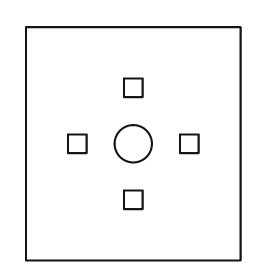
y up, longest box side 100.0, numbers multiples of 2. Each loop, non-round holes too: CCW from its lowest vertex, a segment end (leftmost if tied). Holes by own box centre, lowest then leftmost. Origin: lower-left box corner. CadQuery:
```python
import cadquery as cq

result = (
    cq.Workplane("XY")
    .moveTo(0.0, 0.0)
    .lineTo(92.0, 0.0)
    .lineTo(92.0, 100.0)
    .lineTo(0.0, 100.0)
    .close()
    .moveTo(42.0, 22.0)
    .lineTo(50.0, 22.0)
    .lineTo(50.0, 30.0)
    .lineTo(42.0, 30.0)
    .close()
    .moveTo(18.0, 46.0)
    .lineTo(26.0, 46.0)
    .lineTo(26.0, 54.0)
    .lineTo(18.0, 54.0)
    .close()
    .moveTo(46.0, 50.0)
    .circle(8.0)
    .moveTo(66.0, 46.0)
    .lineTo(74.0, 46.0)
    .lineTo(74.0, 54.0)
    .lineTo(66.0, 54.0)
    .close()
    .moveTo(42.0, 70.0)
    .lineTo(50.0, 70.0)
    .lineTo(50.0, 78.0)
    .lineTo(42.0, 78.0)
    .close()
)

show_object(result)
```